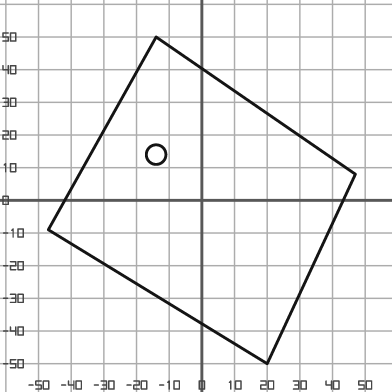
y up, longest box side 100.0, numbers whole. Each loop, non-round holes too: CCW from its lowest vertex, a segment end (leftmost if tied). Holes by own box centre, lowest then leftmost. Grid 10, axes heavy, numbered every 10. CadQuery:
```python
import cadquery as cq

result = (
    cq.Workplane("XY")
    .moveTo(20.0, -50.0)
    .lineTo(47.0, 8.0)
    .lineTo(-14.0, 50.0)
    .lineTo(-47.0, -9.0)
    .close()
    .moveTo(-14.0, 14.0)
    .circle(3.0)
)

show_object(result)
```